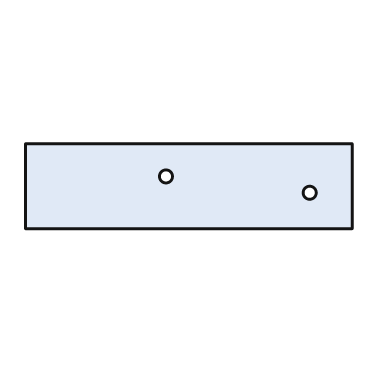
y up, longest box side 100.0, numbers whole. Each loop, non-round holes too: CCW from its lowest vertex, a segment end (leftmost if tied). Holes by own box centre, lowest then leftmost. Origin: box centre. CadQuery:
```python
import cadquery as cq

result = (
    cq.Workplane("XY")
    .moveTo(-50.0, -13.0)
    .lineTo(50.0, -13.0)
    .lineTo(50.0, 13.0)
    .lineTo(-50.0, 13.0)
    .close()
    .moveTo(37.0, -2.0)
    .circle(2.0)
    .moveTo(-7.0, 3.0)
    .circle(2.0)
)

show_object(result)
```